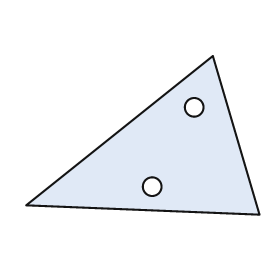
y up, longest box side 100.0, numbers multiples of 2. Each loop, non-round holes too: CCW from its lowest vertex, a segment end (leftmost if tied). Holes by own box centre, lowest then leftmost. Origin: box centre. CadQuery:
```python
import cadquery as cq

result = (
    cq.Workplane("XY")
    .moveTo(50.0, -34.0)
    .lineTo(30.0, 34.0)
    .lineTo(-50.0, -30.0)
    .close()
    .moveTo(4.0, -22.0)
    .circle(4.0)
    .moveTo(22.0, 12.0)
    .circle(4.0)
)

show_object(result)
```